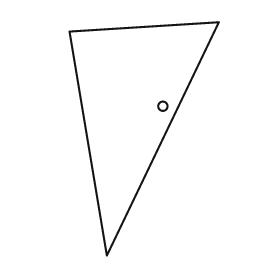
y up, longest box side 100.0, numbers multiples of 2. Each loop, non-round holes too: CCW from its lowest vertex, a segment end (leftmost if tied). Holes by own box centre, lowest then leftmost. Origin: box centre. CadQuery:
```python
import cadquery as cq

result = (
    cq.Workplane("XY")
    .moveTo(-16.0, -50.0)
    .lineTo(32.0, 50.0)
    .lineTo(-32.0, 46.0)
    .close()
    .moveTo(8.0, 14.0)
    .circle(2.0)
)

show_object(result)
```